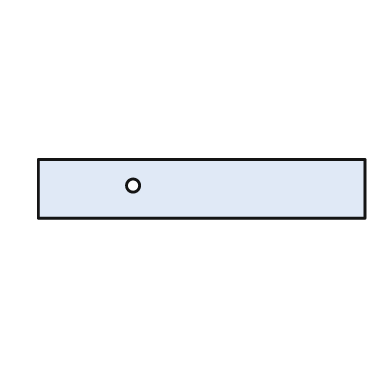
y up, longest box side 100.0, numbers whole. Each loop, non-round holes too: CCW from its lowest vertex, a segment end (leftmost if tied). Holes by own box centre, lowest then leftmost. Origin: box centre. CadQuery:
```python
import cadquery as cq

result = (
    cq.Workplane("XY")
    .moveTo(-50.0, -9.0)
    .lineTo(50.0, -9.0)
    .lineTo(50.0, 9.0)
    .lineTo(-50.0, 9.0)
    .close()
    .moveTo(-21.0, 1.0)
    .circle(2.0)
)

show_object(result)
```